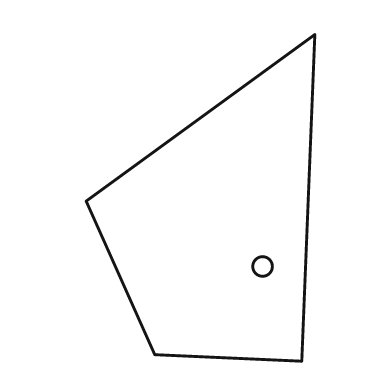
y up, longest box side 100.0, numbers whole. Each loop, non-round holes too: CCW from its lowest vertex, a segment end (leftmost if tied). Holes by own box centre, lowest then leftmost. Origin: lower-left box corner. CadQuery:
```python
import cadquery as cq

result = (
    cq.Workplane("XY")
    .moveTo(66.0, 0.0)
    .lineTo(70.0, 100.0)
    .lineTo(0.0, 49.0)
    .lineTo(21.0, 2.0)
    .close()
    .moveTo(54.0, 29.0)
    .circle(3.0)
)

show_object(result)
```